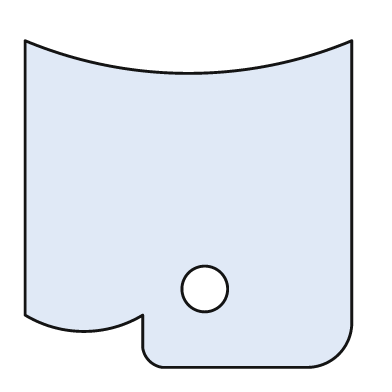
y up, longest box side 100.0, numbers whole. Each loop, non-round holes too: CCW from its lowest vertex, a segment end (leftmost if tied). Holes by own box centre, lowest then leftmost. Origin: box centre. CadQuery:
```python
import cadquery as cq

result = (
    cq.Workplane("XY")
    .moveTo(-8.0, -50.0)
    .lineTo(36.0, -50.0)
    .threePointArc((46.0, -46.0), (50.0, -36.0))
    .lineTo(50.0, 50.0)
    .threePointArc((0.0, 40.0), (-50.0, 50.0))
    .lineTo(-50.0, -34.0)
    .threePointArc((-32.0, -39.0), (-14.0, -34.0))
    .lineTo(-14.0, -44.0)
    .threePointArc((-12.0, -48.0), (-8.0, -50.0))
    .close()
    .moveTo(5.0, -26.0)
    .circle(7.0)
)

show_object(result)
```